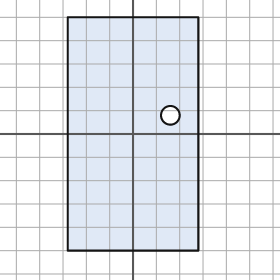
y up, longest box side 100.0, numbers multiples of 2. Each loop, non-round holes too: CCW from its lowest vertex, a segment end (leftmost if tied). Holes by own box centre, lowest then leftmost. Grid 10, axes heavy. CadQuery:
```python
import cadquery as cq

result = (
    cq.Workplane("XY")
    .moveTo(-28.0, -50.0)
    .lineTo(28.0, -50.0)
    .lineTo(28.0, 50.0)
    .lineTo(-28.0, 50.0)
    .close()
    .moveTo(16.0, 8.0)
    .circle(4.0)
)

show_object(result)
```